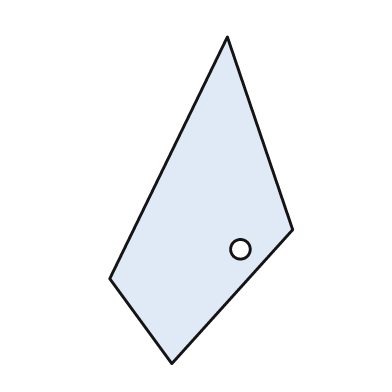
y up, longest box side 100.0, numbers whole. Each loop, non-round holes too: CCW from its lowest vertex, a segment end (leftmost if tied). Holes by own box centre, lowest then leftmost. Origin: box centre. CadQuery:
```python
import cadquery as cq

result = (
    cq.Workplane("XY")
    .moveTo(-9.0, -50.0)
    .lineTo(28.0, -9.0)
    .lineTo(8.0, 50.0)
    .lineTo(-28.0, -24.0)
    .close()
    .moveTo(12.0, -15.0)
    .circle(3.0)
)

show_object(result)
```